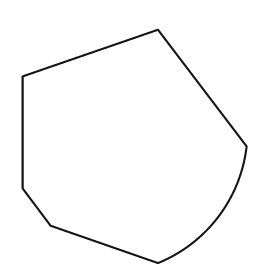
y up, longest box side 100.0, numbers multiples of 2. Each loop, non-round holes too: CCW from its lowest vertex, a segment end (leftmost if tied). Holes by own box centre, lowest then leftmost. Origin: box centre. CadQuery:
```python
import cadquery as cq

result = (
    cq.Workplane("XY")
    .moveTo(10.0, -50.0)
    .threePointArc((36.0, -30.0), (48.0, 0.0))
    .lineTo(10.0, 50.0)
    .lineTo(-48.0, 30.0)
    .lineTo(-48.0, -18.0)
    .lineTo(-36.0, -34.0)
    .close()
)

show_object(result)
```